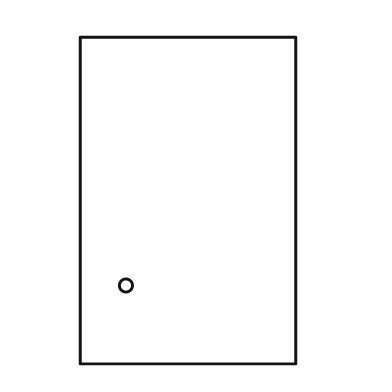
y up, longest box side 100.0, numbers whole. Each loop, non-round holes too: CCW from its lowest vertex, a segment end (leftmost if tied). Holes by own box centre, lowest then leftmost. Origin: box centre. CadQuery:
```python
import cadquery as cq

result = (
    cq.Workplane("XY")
    .moveTo(-33.0, -50.0)
    .lineTo(33.0, -50.0)
    .lineTo(33.0, 50.0)
    .lineTo(-33.0, 50.0)
    .close()
    .moveTo(-19.0, -26.0)
    .circle(2.0)
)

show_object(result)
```